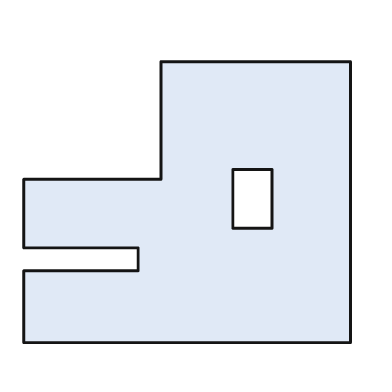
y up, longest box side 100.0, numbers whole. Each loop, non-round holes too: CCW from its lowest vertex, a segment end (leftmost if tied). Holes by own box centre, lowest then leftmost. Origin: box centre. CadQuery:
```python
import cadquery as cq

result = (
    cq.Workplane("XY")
    .moveTo(-50.0, -43.0)
    .lineTo(50.0, -43.0)
    .lineTo(50.0, 43.0)
    .lineTo(-8.0, 43.0)
    .lineTo(-8.0, 7.0)
    .lineTo(-50.0, 7.0)
    .lineTo(-50.0, -14.0)
    .lineTo(-15.0, -14.0)
    .lineTo(-15.0, -21.0)
    .lineTo(-50.0, -21.0)
    .close()
    .moveTo(14.0, -8.0)
    .lineTo(26.0, -8.0)
    .lineTo(26.0, 10.0)
    .lineTo(14.0, 10.0)
    .close()
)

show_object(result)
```